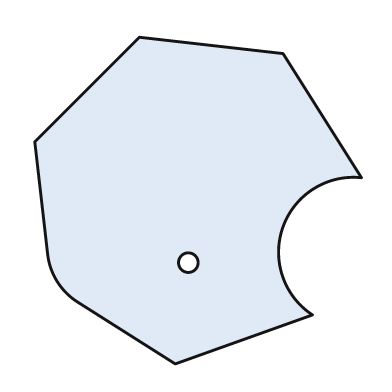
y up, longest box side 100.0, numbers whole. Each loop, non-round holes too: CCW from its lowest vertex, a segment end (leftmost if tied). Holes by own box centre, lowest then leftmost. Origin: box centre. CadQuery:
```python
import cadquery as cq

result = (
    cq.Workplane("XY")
    .moveTo(-7.0, -50.0)
    .lineTo(35.0, -35.0)
    .threePointArc((26.0, -8.0), (50.0, 7.0))
    .lineTo(26.0, 45.0)
    .lineTo(-18.0, 50.0)
    .lineTo(-50.0, 18.0)
    .lineTo(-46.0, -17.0)
    .threePointArc((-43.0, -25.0), (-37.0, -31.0))
    .close()
    .moveTo(-3.0, -19.0)
    .circle(3.0)
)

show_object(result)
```